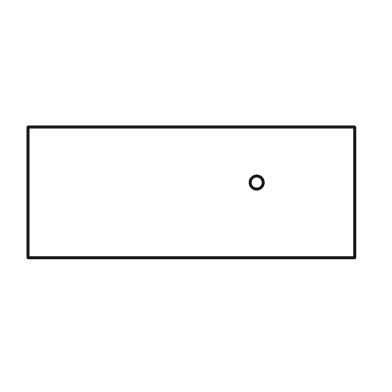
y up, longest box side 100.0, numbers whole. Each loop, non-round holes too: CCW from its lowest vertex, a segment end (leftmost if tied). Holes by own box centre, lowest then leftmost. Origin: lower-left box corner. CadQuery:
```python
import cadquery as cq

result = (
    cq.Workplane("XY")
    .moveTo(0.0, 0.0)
    .lineTo(100.0, 0.0)
    .lineTo(100.0, 40.0)
    .lineTo(0.0, 40.0)
    .close()
    .moveTo(70.0, 23.0)
    .circle(2.0)
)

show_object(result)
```